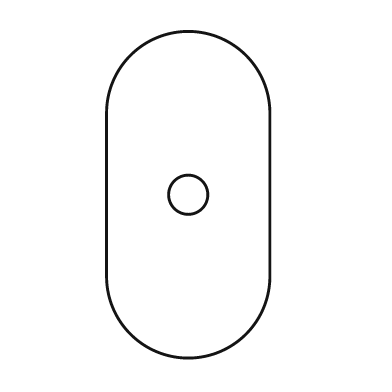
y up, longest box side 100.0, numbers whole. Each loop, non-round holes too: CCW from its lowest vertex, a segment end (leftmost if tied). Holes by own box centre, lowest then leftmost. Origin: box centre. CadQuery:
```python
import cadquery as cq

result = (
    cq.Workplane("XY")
    .moveTo(-25.0, -25.0)
    .threePointArc((0.0, -50.0), (25.0, -25.0))
    .lineTo(25.0, 25.0)
    .threePointArc((0.0, 50.0), (-25.0, 25.0))
    .close()
    .moveTo(0.0, 0.0)
    .circle(6.0)
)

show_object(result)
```